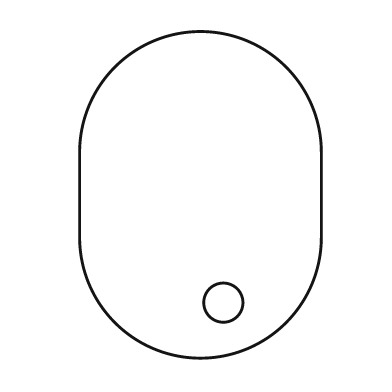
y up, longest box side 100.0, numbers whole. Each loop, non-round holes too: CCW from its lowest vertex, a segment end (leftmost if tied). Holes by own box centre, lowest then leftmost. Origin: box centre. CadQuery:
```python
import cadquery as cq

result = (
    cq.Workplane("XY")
    .moveTo(-37.0, -13.0)
    .threePointArc((0.0, -50.0), (37.0, -13.0))
    .lineTo(37.0, 13.0)
    .threePointArc((0.0, 50.0), (-37.0, 13.0))
    .close()
    .moveTo(7.0, -33.0)
    .circle(6.0)
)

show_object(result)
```